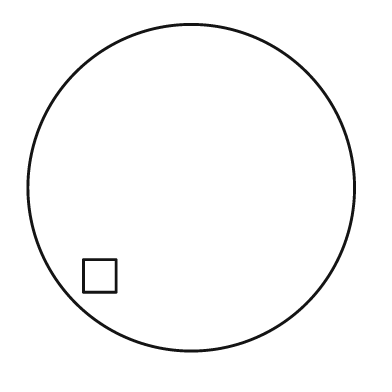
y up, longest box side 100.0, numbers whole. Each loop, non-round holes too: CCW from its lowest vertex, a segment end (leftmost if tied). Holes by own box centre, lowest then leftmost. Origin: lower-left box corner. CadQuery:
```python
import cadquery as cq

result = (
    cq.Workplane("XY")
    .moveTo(50.0, 50.0)
    .circle(50.0)
    .moveTo(17.0, 18.0)
    .lineTo(27.0, 18.0)
    .lineTo(27.0, 28.0)
    .lineTo(17.0, 28.0)
    .close()
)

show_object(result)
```